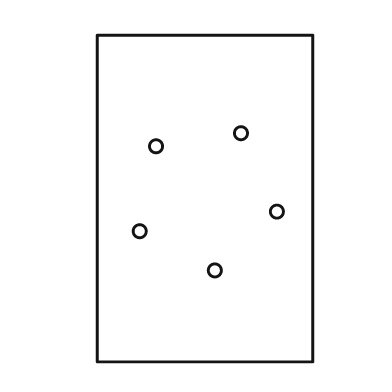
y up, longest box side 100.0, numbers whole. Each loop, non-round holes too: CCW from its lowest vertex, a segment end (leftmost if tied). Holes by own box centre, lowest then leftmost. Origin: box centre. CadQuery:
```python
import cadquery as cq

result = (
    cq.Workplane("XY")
    .moveTo(-33.0, -50.0)
    .lineTo(33.0, -50.0)
    .lineTo(33.0, 50.0)
    .lineTo(-33.0, 50.0)
    .close()
    .moveTo(3.0, -22.0)
    .circle(2.0)
    .moveTo(-20.0, -10.0)
    .circle(2.0)
    .moveTo(22.0, -4.0)
    .circle(2.0)
    .moveTo(-15.0, 16.0)
    .circle(2.0)
    .moveTo(11.0, 20.0)
    .circle(2.0)
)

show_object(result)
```